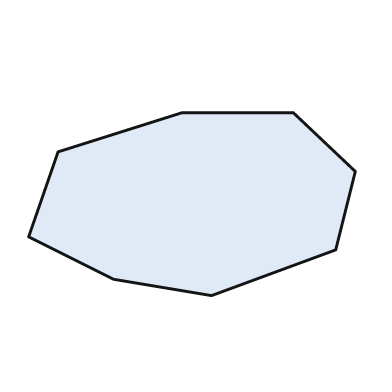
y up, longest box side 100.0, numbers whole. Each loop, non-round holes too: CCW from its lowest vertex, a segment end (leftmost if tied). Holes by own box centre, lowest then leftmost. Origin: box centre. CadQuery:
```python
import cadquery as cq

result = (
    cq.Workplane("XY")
    .moveTo(6.0, -28.0)
    .lineTo(44.0, -14.0)
    .lineTo(50.0, 10.0)
    .lineTo(31.0, 28.0)
    .lineTo(-3.0, 28.0)
    .lineTo(-41.0, 16.0)
    .lineTo(-50.0, -10.0)
    .lineTo(-24.0, -23.0)
    .close()
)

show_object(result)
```